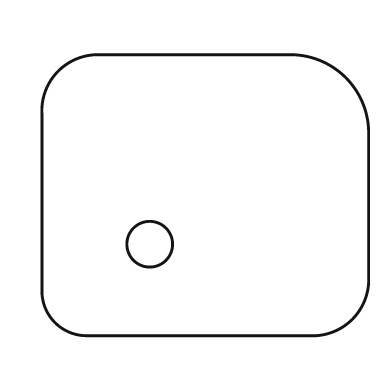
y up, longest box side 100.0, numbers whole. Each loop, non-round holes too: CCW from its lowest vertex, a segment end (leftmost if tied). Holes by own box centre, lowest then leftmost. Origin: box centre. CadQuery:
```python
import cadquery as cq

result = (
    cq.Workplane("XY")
    .moveTo(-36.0, -43.0)
    .lineTo(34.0, -43.0)
    .threePointArc((45.0, -38.0), (50.0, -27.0))
    .lineTo(50.0, 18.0)
    .threePointArc((43.0, 36.0), (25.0, 43.0))
    .lineTo(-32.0, 43.0)
    .threePointArc((-45.0, 38.0), (-50.0, 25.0))
    .lineTo(-50.0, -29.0)
    .threePointArc((-46.0, -39.0), (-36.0, -43.0))
    .close()
    .moveTo(-17.0, -15.0)
    .circle(7.0)
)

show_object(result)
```